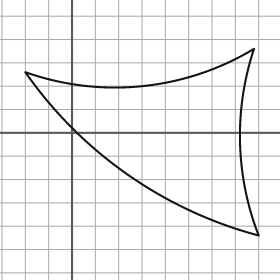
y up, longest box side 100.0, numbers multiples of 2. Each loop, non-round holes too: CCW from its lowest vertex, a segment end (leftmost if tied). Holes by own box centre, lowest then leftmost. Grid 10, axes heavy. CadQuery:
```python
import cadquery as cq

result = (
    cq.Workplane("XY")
    .moveTo(80.0, -44.0)
    .threePointArc((72.0, -4.0), (78.0, 36.0))
    .threePointArc((30.0, 20.0), (-20.0, 26.0))
    .threePointArc((24.0, -18.0), (80.0, -44.0))
    .close()
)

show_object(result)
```